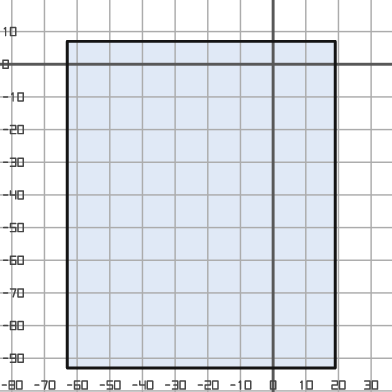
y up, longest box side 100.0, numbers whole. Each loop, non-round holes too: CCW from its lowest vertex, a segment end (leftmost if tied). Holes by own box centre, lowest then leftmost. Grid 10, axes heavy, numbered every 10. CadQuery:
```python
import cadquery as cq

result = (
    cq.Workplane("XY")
    .moveTo(-63.0, -93.0)
    .lineTo(19.0, -93.0)
    .lineTo(19.0, 7.0)
    .lineTo(-63.0, 7.0)
    .close()
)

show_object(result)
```